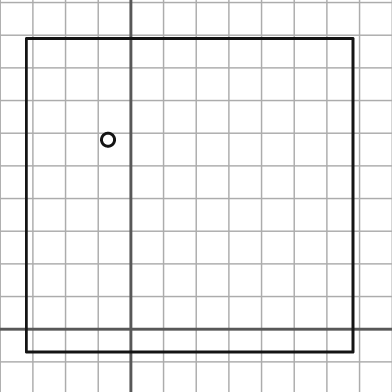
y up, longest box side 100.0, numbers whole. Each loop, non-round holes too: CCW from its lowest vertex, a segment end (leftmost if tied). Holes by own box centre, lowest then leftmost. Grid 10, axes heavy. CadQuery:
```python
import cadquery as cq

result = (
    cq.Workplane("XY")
    .moveTo(-32.0, -7.0)
    .lineTo(68.0, -7.0)
    .lineTo(68.0, 89.0)
    .lineTo(-32.0, 89.0)
    .close()
    .moveTo(-7.0, 58.0)
    .circle(2.0)
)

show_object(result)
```